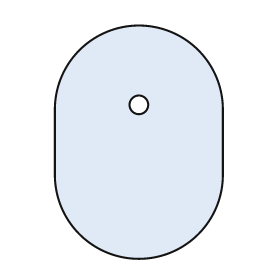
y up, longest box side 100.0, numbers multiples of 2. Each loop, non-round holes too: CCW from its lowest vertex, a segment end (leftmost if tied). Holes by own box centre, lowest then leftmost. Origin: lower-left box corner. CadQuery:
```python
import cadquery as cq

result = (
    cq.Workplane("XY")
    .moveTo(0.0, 36.0)
    .threePointArc((36.0, 0.0), (72.0, 36.0))
    .lineTo(72.0, 64.0)
    .threePointArc((36.0, 100.0), (0.0, 64.0))
    .close()
    .moveTo(36.0, 66.0)
    .circle(4.0)
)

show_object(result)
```